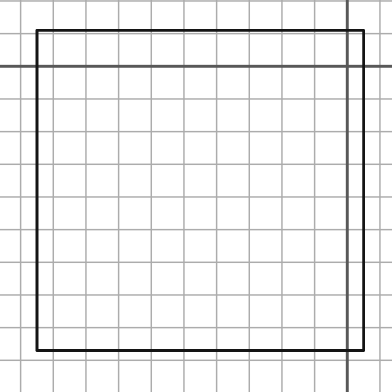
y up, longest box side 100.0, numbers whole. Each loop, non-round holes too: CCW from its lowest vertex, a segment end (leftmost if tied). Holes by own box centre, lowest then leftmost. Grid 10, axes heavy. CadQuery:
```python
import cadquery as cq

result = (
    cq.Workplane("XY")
    .moveTo(-95.0, -87.0)
    .lineTo(5.0, -87.0)
    .lineTo(5.0, 11.0)
    .lineTo(-95.0, 11.0)
    .close()
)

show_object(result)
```